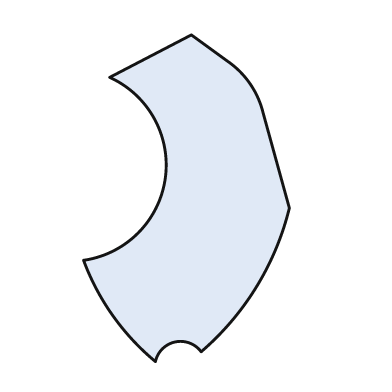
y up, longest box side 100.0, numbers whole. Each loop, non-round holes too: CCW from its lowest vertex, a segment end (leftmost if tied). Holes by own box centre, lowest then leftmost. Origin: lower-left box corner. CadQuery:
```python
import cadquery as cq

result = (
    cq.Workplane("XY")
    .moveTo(22.0, 0.0)
    .threePointArc((28.0, 6.0), (36.0, 3.0))
    .threePointArc((53.0, 23.0), (63.0, 47.0))
    .lineTo(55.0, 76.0)
    .threePointArc((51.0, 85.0), (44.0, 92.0))
    .lineTo(33.0, 100.0)
    .lineTo(8.0, 87.0)
    .threePointArc((25.0, 56.0), (0.0, 31.0))
    .threePointArc((9.0, 14.0), (22.0, 0.0))
    .close()
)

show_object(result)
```